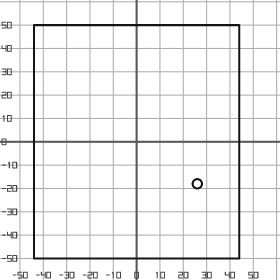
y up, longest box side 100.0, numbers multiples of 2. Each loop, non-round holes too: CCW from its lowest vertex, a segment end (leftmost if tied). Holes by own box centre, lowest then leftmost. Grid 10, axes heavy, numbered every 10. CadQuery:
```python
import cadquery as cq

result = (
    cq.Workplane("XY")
    .moveTo(-44.0, -50.0)
    .lineTo(44.0, -50.0)
    .lineTo(44.0, 50.0)
    .lineTo(-44.0, 50.0)
    .close()
    .moveTo(26.0, -18.0)
    .circle(2.0)
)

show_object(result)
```